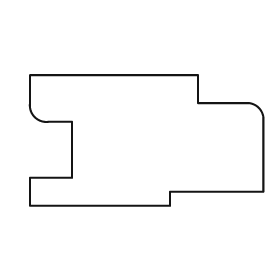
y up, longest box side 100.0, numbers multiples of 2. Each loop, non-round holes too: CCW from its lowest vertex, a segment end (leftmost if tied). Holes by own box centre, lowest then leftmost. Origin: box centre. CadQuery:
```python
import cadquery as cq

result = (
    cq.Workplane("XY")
    .moveTo(-50.0, -28.0)
    .lineTo(10.0, -28.0)
    .lineTo(10.0, -22.0)
    .lineTo(50.0, -22.0)
    .lineTo(50.0, 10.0)
    .threePointArc((48.0, 14.0), (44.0, 16.0))
    .lineTo(22.0, 16.0)
    .lineTo(22.0, 28.0)
    .lineTo(-50.0, 28.0)
    .lineTo(-50.0, 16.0)
    .threePointArc((-48.0, 10.0), (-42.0, 8.0))
    .lineTo(-32.0, 8.0)
    .lineTo(-32.0, -16.0)
    .lineTo(-50.0, -16.0)
    .close()
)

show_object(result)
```